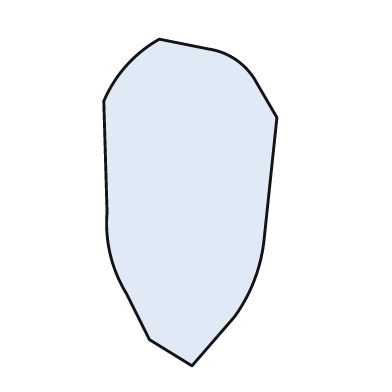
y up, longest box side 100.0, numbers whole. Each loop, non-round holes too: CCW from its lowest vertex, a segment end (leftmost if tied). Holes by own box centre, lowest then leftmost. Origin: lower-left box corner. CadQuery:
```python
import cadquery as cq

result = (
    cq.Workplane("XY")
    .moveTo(27.0, 0.0)
    .lineTo(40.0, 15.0)
    .threePointArc((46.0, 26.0), (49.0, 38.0))
    .lineTo(53.0, 76.0)
    .lineTo(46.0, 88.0)
    .threePointArc((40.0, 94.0), (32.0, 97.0))
    .lineTo(17.0, 100.0)
    .threePointArc((7.0, 92.0), (0.0, 81.0))
    .lineTo(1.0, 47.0)
    .threePointArc((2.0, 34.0), (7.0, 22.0))
    .lineTo(14.0, 8.0)
    .close()
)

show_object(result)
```